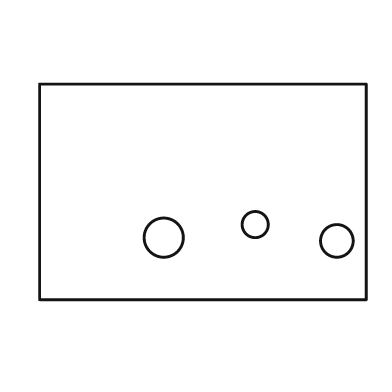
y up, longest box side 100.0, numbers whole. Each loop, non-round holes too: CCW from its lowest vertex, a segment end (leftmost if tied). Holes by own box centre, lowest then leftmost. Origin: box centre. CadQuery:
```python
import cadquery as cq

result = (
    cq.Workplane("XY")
    .moveTo(-50.0, -33.0)
    .lineTo(50.0, -33.0)
    .lineTo(50.0, 33.0)
    .lineTo(-50.0, 33.0)
    .close()
    .moveTo(41.0, -15.0)
    .circle(5.0)
    .moveTo(-12.0, -14.0)
    .circle(6.0)
    .moveTo(16.0, -10.0)
    .circle(4.0)
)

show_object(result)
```